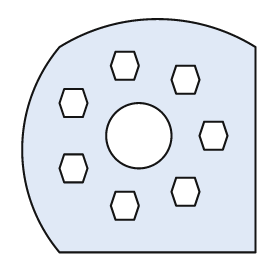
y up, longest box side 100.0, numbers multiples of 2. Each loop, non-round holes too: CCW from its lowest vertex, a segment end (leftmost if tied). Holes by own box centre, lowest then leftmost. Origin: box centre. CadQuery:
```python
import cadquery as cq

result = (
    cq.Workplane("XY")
    .moveTo(-34.0, -50.0)
    .lineTo(50.0, -50.0)
    .lineTo(50.0, 38.0)
    .threePointArc((8.0, 50.0), (-34.0, 38.0))
    .threePointArc((-50.0, -6.0), (-34.0, -50.0))
    .close()
    .moveTo(-10.0, -36.0)
    .lineTo(-2.0, -36.0)
    .lineTo(0.0, -30.0)
    .lineTo(-2.0, -24.0)
    .lineTo(-10.0, -24.0)
    .lineTo(-12.0, -30.0)
    .close()
    .moveTo(16.0, -30.0)
    .lineTo(24.0, -30.0)
    .lineTo(26.0, -24.0)
    .lineTo(24.0, -18.0)
    .lineTo(16.0, -18.0)
    .lineTo(14.0, -24.0)
    .close()
    .moveTo(-32.0, -20.0)
    .lineTo(-24.0, -20.0)
    .lineTo(-22.0, -14.0)
    .lineTo(-24.0, -8.0)
    .lineTo(-32.0, -8.0)
    .lineTo(-34.0, -14.0)
    .close()
    .moveTo(0.0, 0.0)
    .circle(14.0)
    .moveTo(28.0, -6.0)
    .lineTo(36.0, -6.0)
    .lineTo(38.0, 0.0)
    .lineTo(36.0, 6.0)
    .lineTo(28.0, 6.0)
    .lineTo(26.0, 0.0)
    .close()
    .moveTo(-32.0, 8.0)
    .lineTo(-24.0, 8.0)
    .lineTo(-22.0, 14.0)
    .lineTo(-24.0, 20.0)
    .lineTo(-32.0, 20.0)
    .lineTo(-34.0, 14.0)
    .close()
    .moveTo(16.0, 18.0)
    .lineTo(24.0, 18.0)
    .lineTo(26.0, 24.0)
    .lineTo(24.0, 30.0)
    .lineTo(16.0, 30.0)
    .lineTo(14.0, 24.0)
    .close()
    .moveTo(-10.0, 24.0)
    .lineTo(-2.0, 24.0)
    .lineTo(0.0, 30.0)
    .lineTo(-2.0, 36.0)
    .lineTo(-10.0, 36.0)
    .lineTo(-12.0, 30.0)
    .close()
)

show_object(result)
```